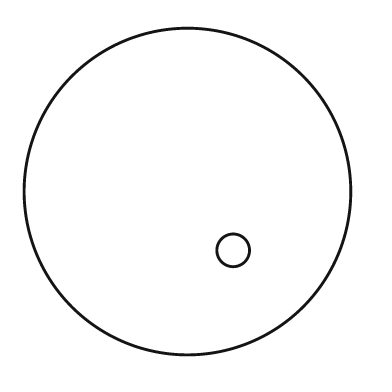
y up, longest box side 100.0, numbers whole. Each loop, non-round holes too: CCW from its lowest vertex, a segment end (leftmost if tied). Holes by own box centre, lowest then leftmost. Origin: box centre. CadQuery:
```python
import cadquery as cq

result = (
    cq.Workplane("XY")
    .moveTo(0.0, 0.0)
    .circle(50.0)
    .moveTo(14.0, -18.0)
    .circle(5.0)
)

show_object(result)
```